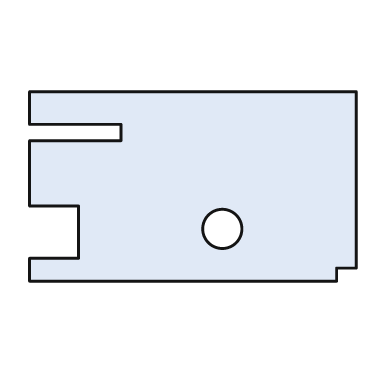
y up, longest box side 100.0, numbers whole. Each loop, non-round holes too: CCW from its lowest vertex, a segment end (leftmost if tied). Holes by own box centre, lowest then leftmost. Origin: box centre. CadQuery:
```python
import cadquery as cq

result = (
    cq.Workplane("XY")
    .moveTo(-50.0, -29.0)
    .lineTo(44.0, -29.0)
    .lineTo(44.0, -25.0)
    .lineTo(50.0, -25.0)
    .lineTo(50.0, 29.0)
    .lineTo(-50.0, 29.0)
    .lineTo(-50.0, 19.0)
    .lineTo(-22.0, 19.0)
    .lineTo(-22.0, 14.0)
    .lineTo(-50.0, 14.0)
    .lineTo(-50.0, -6.0)
    .lineTo(-35.0, -6.0)
    .lineTo(-35.0, -22.0)
    .lineTo(-50.0, -22.0)
    .close()
    .moveTo(9.0, -13.0)
    .circle(6.0)
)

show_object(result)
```